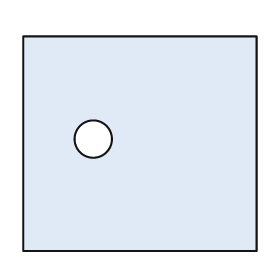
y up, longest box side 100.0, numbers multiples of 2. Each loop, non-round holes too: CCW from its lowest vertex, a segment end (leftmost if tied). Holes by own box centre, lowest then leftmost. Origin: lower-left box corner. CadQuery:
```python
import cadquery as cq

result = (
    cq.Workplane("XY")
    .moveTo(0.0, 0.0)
    .lineTo(100.0, 0.0)
    .lineTo(100.0, 92.0)
    .lineTo(0.0, 92.0)
    .close()
    .moveTo(30.0, 48.0)
    .circle(8.0)
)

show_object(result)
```